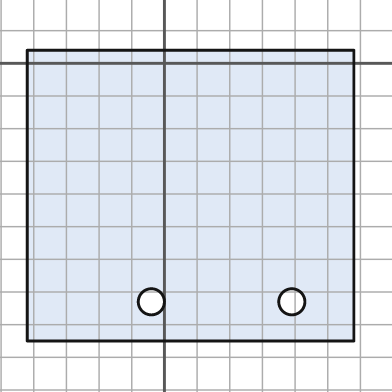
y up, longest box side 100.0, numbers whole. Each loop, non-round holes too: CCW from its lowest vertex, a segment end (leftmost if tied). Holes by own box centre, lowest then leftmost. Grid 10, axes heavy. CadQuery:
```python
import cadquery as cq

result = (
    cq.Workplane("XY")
    .moveTo(-42.0, -85.0)
    .lineTo(58.0, -85.0)
    .lineTo(58.0, 4.0)
    .lineTo(-42.0, 4.0)
    .close()
    .moveTo(-4.0, -73.0)
    .circle(4.0)
    .moveTo(39.0, -73.0)
    .circle(4.0)
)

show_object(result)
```